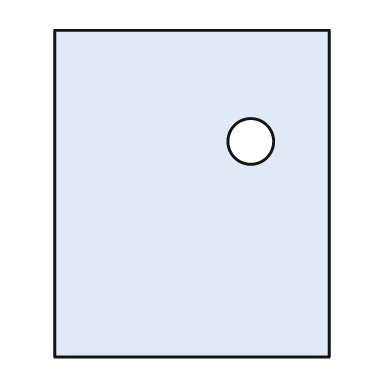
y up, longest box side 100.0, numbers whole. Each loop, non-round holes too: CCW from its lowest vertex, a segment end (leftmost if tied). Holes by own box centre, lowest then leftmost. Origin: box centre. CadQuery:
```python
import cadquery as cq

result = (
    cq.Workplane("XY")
    .moveTo(-42.0, -50.0)
    .lineTo(42.0, -50.0)
    .lineTo(42.0, 50.0)
    .lineTo(-42.0, 50.0)
    .close()
    .moveTo(18.0, 16.0)
    .circle(7.0)
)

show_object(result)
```